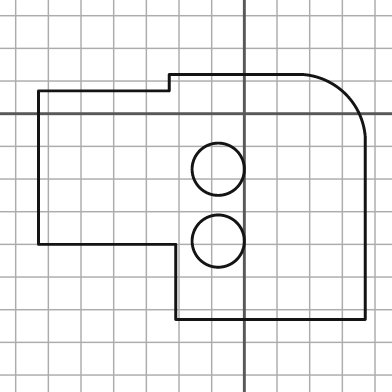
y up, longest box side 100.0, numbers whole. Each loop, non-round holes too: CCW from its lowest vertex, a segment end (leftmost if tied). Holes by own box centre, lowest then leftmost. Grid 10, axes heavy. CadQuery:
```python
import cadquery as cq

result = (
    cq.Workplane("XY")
    .moveTo(-21.0, -63.0)
    .lineTo(37.0, -63.0)
    .lineTo(37.0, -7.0)
    .threePointArc((31.0, 6.0), (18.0, 12.0))
    .lineTo(-23.0, 12.0)
    .lineTo(-23.0, 7.0)
    .lineTo(-63.0, 7.0)
    .lineTo(-63.0, -40.0)
    .lineTo(-21.0, -40.0)
    .close()
    .moveTo(-8.0, -39.0)
    .circle(8.0)
    .moveTo(-8.0, -17.0)
    .circle(8.0)
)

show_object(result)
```